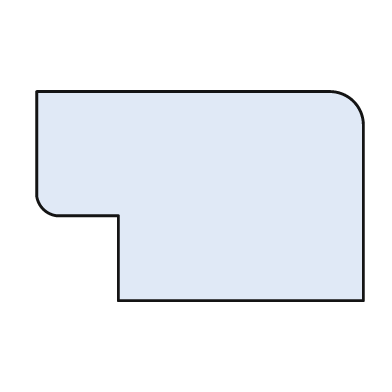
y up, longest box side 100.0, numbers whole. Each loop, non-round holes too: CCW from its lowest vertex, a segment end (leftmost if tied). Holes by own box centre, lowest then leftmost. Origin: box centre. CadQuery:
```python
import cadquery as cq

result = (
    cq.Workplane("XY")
    .moveTo(-25.0, -32.0)
    .lineTo(50.0, -32.0)
    .lineTo(50.0, 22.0)
    .threePointArc((47.0, 29.0), (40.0, 32.0))
    .lineTo(-50.0, 32.0)
    .lineTo(-50.0, 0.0)
    .threePointArc((-48.0, -4.0), (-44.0, -6.0))
    .lineTo(-25.0, -6.0)
    .close()
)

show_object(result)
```